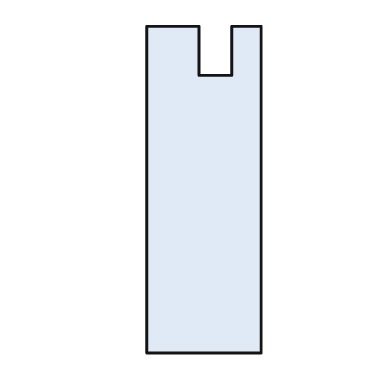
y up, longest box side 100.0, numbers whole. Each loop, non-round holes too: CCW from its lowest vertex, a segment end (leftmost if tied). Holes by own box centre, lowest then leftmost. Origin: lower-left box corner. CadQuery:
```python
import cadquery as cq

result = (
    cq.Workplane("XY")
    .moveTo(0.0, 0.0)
    .lineTo(35.0, 0.0)
    .lineTo(35.0, 100.0)
    .lineTo(26.0, 100.0)
    .lineTo(26.0, 85.0)
    .lineTo(16.0, 85.0)
    .lineTo(16.0, 100.0)
    .lineTo(0.0, 100.0)
    .close()
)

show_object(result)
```